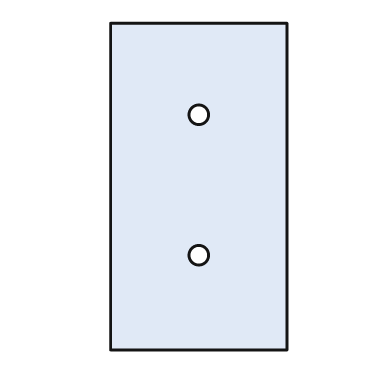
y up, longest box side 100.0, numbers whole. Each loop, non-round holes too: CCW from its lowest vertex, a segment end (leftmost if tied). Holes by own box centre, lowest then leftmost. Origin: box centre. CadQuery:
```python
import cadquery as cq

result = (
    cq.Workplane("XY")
    .moveTo(-27.0, -50.0)
    .lineTo(27.0, -50.0)
    .lineTo(27.0, 50.0)
    .lineTo(-27.0, 50.0)
    .close()
    .moveTo(0.0, -21.0)
    .circle(3.0)
    .moveTo(0.0, 22.0)
    .circle(3.0)
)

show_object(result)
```